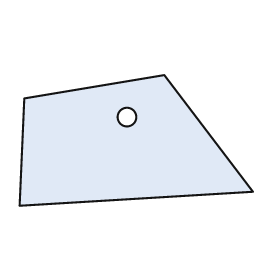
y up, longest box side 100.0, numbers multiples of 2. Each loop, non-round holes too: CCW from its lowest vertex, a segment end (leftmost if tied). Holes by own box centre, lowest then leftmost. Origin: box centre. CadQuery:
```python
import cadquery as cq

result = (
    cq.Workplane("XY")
    .moveTo(-50.0, -28.0)
    .lineTo(50.0, -22.0)
    .lineTo(12.0, 28.0)
    .lineTo(-48.0, 18.0)
    .close()
    .moveTo(-4.0, 10.0)
    .circle(4.0)
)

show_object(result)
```